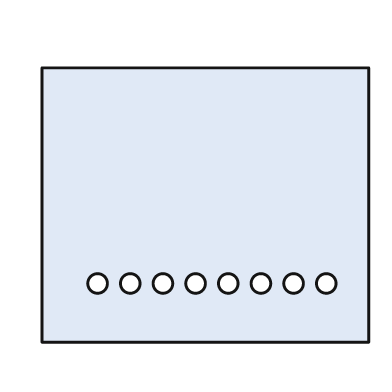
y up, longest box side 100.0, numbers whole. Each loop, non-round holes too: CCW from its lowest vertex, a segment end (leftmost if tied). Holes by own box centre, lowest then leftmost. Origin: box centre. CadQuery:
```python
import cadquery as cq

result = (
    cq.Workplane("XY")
    .moveTo(-50.0, -42.0)
    .lineTo(50.0, -42.0)
    .lineTo(50.0, 42.0)
    .lineTo(-50.0, 42.0)
    .close()
    .moveTo(-33.0, -24.0)
    .circle(3.0)
    .moveTo(-23.0, -24.0)
    .circle(3.0)
    .moveTo(-13.0, -24.0)
    .circle(3.0)
    .moveTo(-3.0, -24.0)
    .circle(3.0)
    .moveTo(7.0, -24.0)
    .circle(3.0)
    .moveTo(17.0, -24.0)
    .circle(3.0)
    .moveTo(27.0, -24.0)
    .circle(3.0)
    .moveTo(37.0, -24.0)
    .circle(3.0)
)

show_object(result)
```